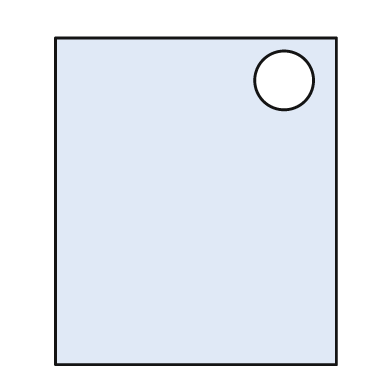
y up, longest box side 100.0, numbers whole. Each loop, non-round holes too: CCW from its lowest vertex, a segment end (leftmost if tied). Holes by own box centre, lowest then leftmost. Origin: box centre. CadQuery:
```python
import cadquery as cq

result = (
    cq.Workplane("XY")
    .moveTo(-43.0, -50.0)
    .lineTo(43.0, -50.0)
    .lineTo(43.0, 50.0)
    .lineTo(-43.0, 50.0)
    .close()
    .moveTo(27.0, 37.0)
    .circle(9.0)
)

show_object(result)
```